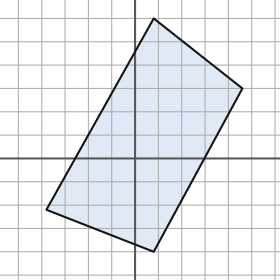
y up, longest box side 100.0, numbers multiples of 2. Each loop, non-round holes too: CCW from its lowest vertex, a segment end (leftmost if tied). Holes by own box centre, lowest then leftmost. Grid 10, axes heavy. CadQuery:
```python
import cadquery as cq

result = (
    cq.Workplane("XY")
    .moveTo(8.0, -40.0)
    .lineTo(46.0, 30.0)
    .lineTo(8.0, 60.0)
    .lineTo(-38.0, -22.0)
    .close()
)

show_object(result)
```